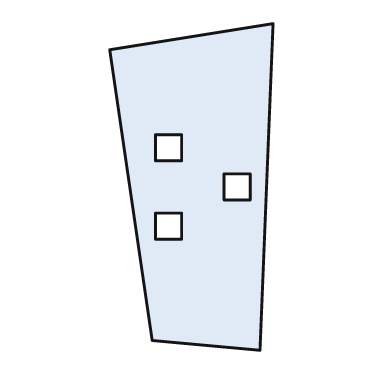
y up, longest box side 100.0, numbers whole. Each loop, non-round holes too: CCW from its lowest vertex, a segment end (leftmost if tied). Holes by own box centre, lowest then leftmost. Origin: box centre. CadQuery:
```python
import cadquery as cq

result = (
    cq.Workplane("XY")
    .moveTo(21.0, -50.0)
    .lineTo(25.0, 50.0)
    .lineTo(-25.0, 42.0)
    .lineTo(-12.0, -47.0)
    .close()
    .moveTo(-11.0, -16.0)
    .lineTo(-3.0, -16.0)
    .lineTo(-3.0, -8.0)
    .lineTo(-11.0, -8.0)
    .close()
    .moveTo(10.0, -4.0)
    .lineTo(18.0, -4.0)
    .lineTo(18.0, 4.0)
    .lineTo(10.0, 4.0)
    .close()
    .moveTo(-11.0, 8.0)
    .lineTo(-3.0, 8.0)
    .lineTo(-3.0, 16.0)
    .lineTo(-11.0, 16.0)
    .close()
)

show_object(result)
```